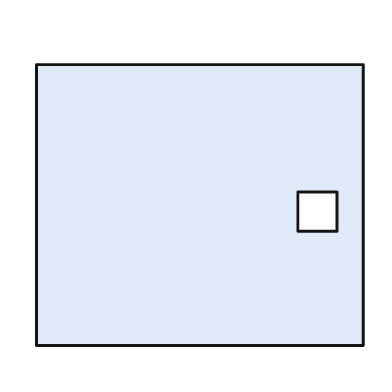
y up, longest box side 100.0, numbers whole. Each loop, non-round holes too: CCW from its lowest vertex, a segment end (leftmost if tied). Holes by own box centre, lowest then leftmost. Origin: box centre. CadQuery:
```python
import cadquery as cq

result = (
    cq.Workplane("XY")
    .moveTo(-50.0, -43.0)
    .lineTo(50.0, -43.0)
    .lineTo(50.0, 43.0)
    .lineTo(-50.0, 43.0)
    .close()
    .moveTo(30.0, -8.0)
    .lineTo(42.0, -8.0)
    .lineTo(42.0, 4.0)
    .lineTo(30.0, 4.0)
    .close()
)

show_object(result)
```